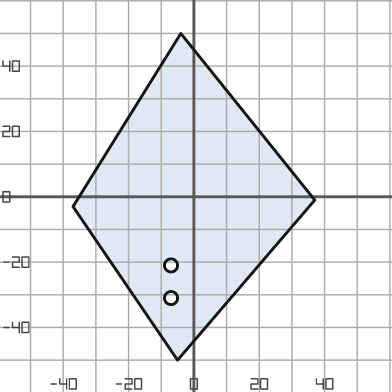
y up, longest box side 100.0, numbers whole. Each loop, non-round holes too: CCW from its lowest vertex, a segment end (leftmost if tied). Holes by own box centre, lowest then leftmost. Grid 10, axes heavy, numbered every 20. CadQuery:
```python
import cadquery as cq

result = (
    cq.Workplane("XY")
    .moveTo(-5.0, -50.0)
    .lineTo(37.0, -1.0)
    .lineTo(-4.0, 50.0)
    .lineTo(-37.0, -3.0)
    .close()
    .moveTo(-7.0, -31.0)
    .circle(2.0)
    .moveTo(-7.0, -21.0)
    .circle(2.0)
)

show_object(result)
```